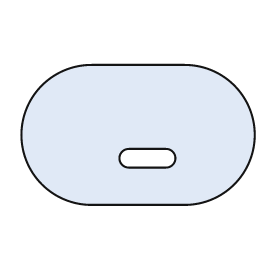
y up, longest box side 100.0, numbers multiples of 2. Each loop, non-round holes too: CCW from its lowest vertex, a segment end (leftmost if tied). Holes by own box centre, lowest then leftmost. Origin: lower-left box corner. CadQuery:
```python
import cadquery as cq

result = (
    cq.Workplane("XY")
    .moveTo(30.0, 0.0)
    .lineTo(70.0, 0.0)
    .threePointArc((100.0, 30.0), (70.0, 60.0))
    .lineTo(30.0, 60.0)
    .threePointArc((0.0, 30.0), (30.0, 0.0))
    .close()
    .moveTo(46.0, 16.0)
    .lineTo(62.0, 16.0)
    .threePointArc((66.0, 20.0), (62.0, 24.0))
    .lineTo(46.0, 24.0)
    .threePointArc((42.0, 20.0), (46.0, 16.0))
    .close()
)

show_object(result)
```